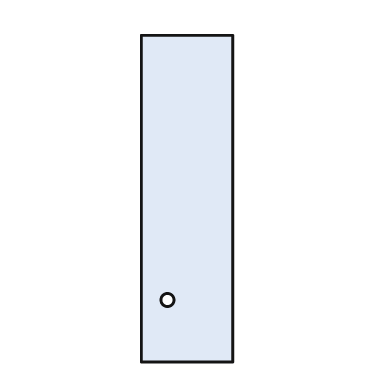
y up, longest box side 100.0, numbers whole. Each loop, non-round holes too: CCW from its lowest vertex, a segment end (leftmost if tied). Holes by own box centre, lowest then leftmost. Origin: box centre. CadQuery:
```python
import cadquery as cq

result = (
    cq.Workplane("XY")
    .moveTo(-14.0, -50.0)
    .lineTo(14.0, -50.0)
    .lineTo(14.0, 50.0)
    .lineTo(-14.0, 50.0)
    .close()
    .moveTo(-6.0, -31.0)
    .circle(2.0)
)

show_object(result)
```